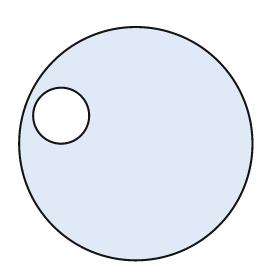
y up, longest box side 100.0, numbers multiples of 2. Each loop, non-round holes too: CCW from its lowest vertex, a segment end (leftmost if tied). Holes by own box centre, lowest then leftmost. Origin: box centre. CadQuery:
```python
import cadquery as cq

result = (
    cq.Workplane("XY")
    .moveTo(0.0, 0.0)
    .circle(50.0)
    .moveTo(-32.0, 12.0)
    .circle(12.0)
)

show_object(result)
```